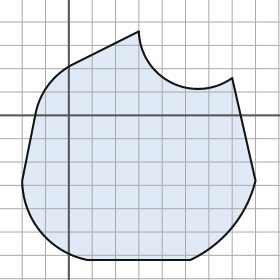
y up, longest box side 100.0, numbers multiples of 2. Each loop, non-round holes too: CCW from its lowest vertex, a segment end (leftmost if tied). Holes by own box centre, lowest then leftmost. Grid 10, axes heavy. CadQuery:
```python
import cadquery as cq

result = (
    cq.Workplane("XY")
    .moveTo(8.0, -62.0)
    .lineTo(52.0, -62.0)
    .threePointArc((70.0, -48.0), (80.0, -28.0))
    .lineTo(70.0, 16.0)
    .threePointArc((44.0, 14.0), (30.0, 36.0))
    .lineTo(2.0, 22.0)
    .threePointArc((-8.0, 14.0), (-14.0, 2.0))
    .lineTo(-20.0, -28.0)
    .threePointArc((-12.0, -50.0), (8.0, -62.0))
    .close()
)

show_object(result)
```